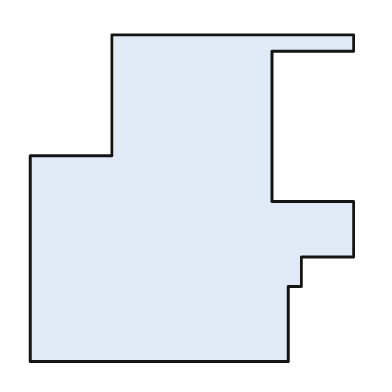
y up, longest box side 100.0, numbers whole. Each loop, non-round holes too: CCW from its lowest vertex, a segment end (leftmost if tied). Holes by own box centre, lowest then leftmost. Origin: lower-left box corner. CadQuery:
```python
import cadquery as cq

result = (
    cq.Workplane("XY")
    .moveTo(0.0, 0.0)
    .lineTo(79.0, 0.0)
    .lineTo(79.0, 23.0)
    .lineTo(83.0, 23.0)
    .lineTo(83.0, 32.0)
    .lineTo(99.0, 32.0)
    .lineTo(99.0, 49.0)
    .lineTo(74.0, 49.0)
    .lineTo(74.0, 95.0)
    .lineTo(99.0, 95.0)
    .lineTo(99.0, 100.0)
    .lineTo(25.0, 100.0)
    .lineTo(25.0, 63.0)
    .lineTo(0.0, 63.0)
    .close()
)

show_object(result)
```